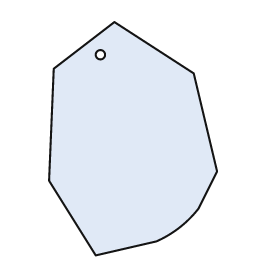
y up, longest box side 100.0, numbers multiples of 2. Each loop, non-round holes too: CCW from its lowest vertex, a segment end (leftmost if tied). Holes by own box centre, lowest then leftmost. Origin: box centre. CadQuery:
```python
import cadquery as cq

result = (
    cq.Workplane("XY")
    .moveTo(-16.0, -50.0)
    .lineTo(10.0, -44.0)
    .threePointArc((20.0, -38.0), (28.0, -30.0))
    .lineTo(36.0, -14.0)
    .lineTo(26.0, 28.0)
    .lineTo(-8.0, 50.0)
    .lineTo(-34.0, 30.0)
    .lineTo(-36.0, -18.0)
    .close()
    .moveTo(-14.0, 36.0)
    .circle(2.0)
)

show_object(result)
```